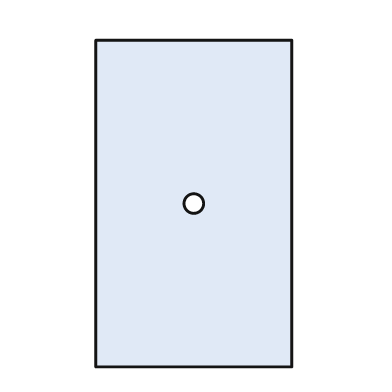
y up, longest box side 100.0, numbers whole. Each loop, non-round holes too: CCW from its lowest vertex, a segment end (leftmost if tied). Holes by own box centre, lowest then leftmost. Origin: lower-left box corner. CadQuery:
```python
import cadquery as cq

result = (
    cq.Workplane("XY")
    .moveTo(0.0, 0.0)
    .lineTo(60.0, 0.0)
    .lineTo(60.0, 100.0)
    .lineTo(0.0, 100.0)
    .close()
    .moveTo(30.0, 50.0)
    .circle(3.0)
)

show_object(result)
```